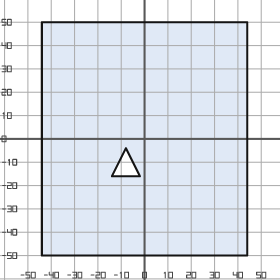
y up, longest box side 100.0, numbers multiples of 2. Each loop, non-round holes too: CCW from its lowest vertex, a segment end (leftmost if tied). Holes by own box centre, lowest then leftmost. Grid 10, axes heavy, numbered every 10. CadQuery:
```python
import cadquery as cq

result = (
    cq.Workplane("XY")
    .moveTo(-44.0, -50.0)
    .lineTo(44.0, -50.0)
    .lineTo(44.0, 50.0)
    .lineTo(-44.0, 50.0)
    .close()
    .moveTo(-14.0, -16.0)
    .lineTo(-2.0, -16.0)
    .lineTo(-8.0, -4.0)
    .close()
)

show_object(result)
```